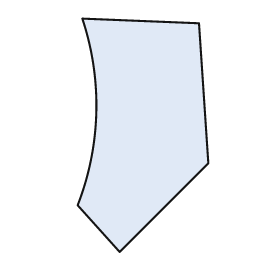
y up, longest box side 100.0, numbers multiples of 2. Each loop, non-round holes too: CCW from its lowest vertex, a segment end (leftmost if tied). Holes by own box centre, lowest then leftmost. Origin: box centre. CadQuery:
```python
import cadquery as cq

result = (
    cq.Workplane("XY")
    .moveTo(-10.0, -50.0)
    .lineTo(28.0, -12.0)
    .lineTo(24.0, 48.0)
    .lineTo(-26.0, 50.0)
    .threePointArc((-20.0, 10.0), (-28.0, -30.0))
    .close()
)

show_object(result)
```